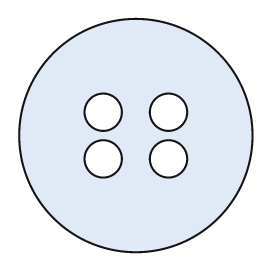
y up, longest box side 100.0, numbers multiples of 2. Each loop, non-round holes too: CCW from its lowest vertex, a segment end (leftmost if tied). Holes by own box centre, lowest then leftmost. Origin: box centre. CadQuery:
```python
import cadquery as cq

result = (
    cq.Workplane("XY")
    .moveTo(0.0, 0.0)
    .circle(50.0)
    .moveTo(-14.0, -10.0)
    .circle(8.0)
    .moveTo(14.0, -10.0)
    .circle(8.0)
    .moveTo(-14.0, 10.0)
    .circle(8.0)
    .moveTo(14.0, 10.0)
    .circle(8.0)
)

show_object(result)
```